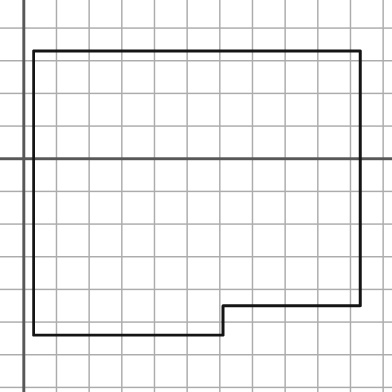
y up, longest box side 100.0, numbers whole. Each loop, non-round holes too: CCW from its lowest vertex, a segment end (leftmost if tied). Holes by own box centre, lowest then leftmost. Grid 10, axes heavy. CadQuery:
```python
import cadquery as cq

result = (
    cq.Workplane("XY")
    .moveTo(3.0, -54.0)
    .lineTo(61.0, -54.0)
    .lineTo(61.0, -45.0)
    .lineTo(103.0, -45.0)
    .lineTo(103.0, 33.0)
    .lineTo(3.0, 33.0)
    .close()
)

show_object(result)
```